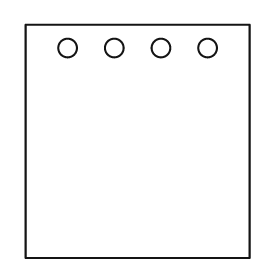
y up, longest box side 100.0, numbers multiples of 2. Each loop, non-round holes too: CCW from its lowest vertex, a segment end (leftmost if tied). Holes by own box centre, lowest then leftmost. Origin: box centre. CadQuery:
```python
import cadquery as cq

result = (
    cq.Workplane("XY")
    .moveTo(-48.0, -50.0)
    .lineTo(48.0, -50.0)
    .lineTo(48.0, 50.0)
    .lineTo(-48.0, 50.0)
    .close()
    .moveTo(-30.0, 40.0)
    .circle(4.0)
    .moveTo(-10.0, 40.0)
    .circle(4.0)
    .moveTo(10.0, 40.0)
    .circle(4.0)
    .moveTo(30.0, 40.0)
    .circle(4.0)
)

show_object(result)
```